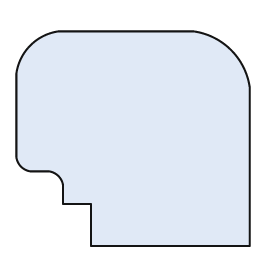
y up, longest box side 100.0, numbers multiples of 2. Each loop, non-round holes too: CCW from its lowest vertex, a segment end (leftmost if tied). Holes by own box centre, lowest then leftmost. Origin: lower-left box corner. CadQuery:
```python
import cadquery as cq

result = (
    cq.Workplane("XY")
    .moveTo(32.0, 0.0)
    .lineTo(100.0, 0.0)
    .lineTo(100.0, 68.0)
    .threePointArc((92.0, 84.0), (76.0, 92.0))
    .lineTo(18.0, 92.0)
    .threePointArc((6.0, 86.0), (0.0, 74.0))
    .lineTo(0.0, 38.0)
    .threePointArc((2.0, 34.0), (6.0, 32.0))
    .lineTo(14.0, 32.0)
    .threePointArc((18.0, 30.0), (20.0, 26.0))
    .lineTo(20.0, 18.0)
    .lineTo(32.0, 18.0)
    .close()
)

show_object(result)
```